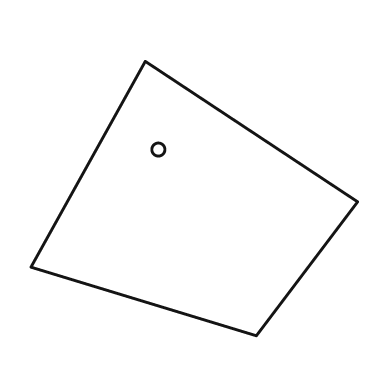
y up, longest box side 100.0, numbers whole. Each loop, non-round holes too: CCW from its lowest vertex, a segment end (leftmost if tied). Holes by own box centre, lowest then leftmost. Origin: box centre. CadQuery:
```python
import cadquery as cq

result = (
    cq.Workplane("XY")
    .moveTo(19.0, -42.0)
    .lineTo(50.0, -1.0)
    .lineTo(-15.0, 42.0)
    .lineTo(-50.0, -21.0)
    .close()
    .moveTo(-11.0, 15.0)
    .circle(2.0)
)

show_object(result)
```